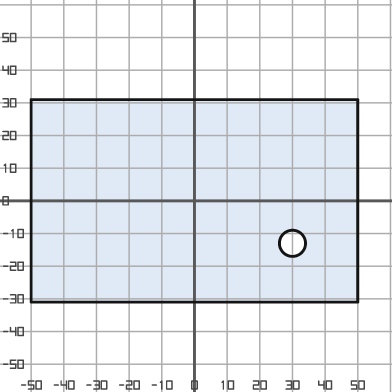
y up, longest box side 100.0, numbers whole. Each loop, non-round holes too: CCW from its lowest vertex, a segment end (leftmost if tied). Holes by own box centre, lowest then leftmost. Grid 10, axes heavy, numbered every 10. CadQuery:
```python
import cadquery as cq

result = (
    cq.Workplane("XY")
    .moveTo(-50.0, -31.0)
    .lineTo(50.0, -31.0)
    .lineTo(50.0, 31.0)
    .lineTo(-50.0, 31.0)
    .close()
    .moveTo(30.0, -13.0)
    .circle(4.0)
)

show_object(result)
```